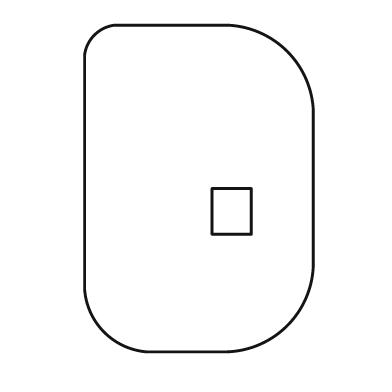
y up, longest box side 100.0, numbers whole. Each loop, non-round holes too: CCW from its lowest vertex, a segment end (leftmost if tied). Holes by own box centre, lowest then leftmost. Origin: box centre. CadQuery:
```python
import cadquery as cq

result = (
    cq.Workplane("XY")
    .moveTo(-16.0, -50.0)
    .lineTo(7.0, -50.0)
    .threePointArc((27.0, -42.0), (35.0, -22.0))
    .lineTo(35.0, 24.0)
    .threePointArc((27.0, 42.0), (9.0, 50.0))
    .lineTo(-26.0, 50.0)
    .threePointArc((-32.0, 47.0), (-35.0, 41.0))
    .lineTo(-35.0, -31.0)
    .threePointArc((-29.0, -44.0), (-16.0, -50.0))
    .close()
    .moveTo(4.0, -14.0)
    .lineTo(16.0, -14.0)
    .lineTo(16.0, 0.0)
    .lineTo(4.0, 0.0)
    .close()
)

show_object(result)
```